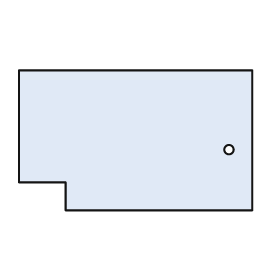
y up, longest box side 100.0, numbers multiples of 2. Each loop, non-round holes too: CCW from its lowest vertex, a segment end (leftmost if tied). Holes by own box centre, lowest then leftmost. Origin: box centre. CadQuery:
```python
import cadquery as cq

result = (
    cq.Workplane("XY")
    .moveTo(-30.0, -30.0)
    .lineTo(50.0, -30.0)
    .lineTo(50.0, 30.0)
    .lineTo(-50.0, 30.0)
    .lineTo(-50.0, -18.0)
    .lineTo(-30.0, -18.0)
    .close()
    .moveTo(40.0, -4.0)
    .circle(2.0)
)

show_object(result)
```